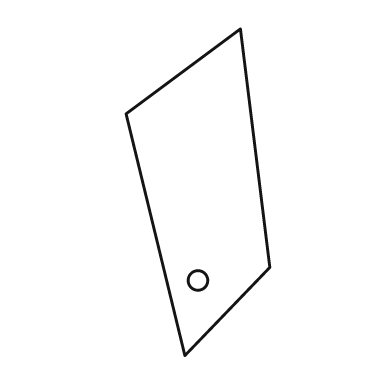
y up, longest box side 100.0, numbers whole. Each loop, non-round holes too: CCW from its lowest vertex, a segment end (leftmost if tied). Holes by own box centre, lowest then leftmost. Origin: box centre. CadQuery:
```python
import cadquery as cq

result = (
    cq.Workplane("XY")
    .moveTo(-4.0, -50.0)
    .lineTo(22.0, -23.0)
    .lineTo(13.0, 50.0)
    .lineTo(-22.0, 24.0)
    .close()
    .moveTo(0.0, -27.0)
    .circle(3.0)
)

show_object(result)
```